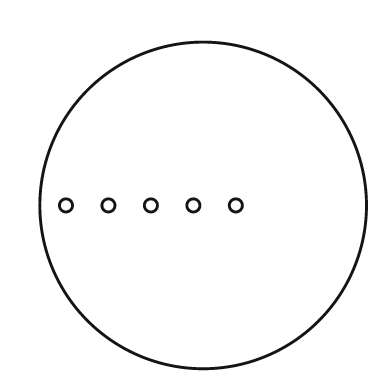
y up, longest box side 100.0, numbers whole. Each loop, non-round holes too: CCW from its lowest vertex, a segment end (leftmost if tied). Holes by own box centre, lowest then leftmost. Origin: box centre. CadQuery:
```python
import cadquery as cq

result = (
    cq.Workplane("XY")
    .moveTo(0.0, 0.0)
    .circle(50.0)
    .moveTo(-42.0, 0.0)
    .circle(2.0)
    .moveTo(-29.0, 0.0)
    .circle(2.0)
    .moveTo(-16.0, 0.0)
    .circle(2.0)
    .moveTo(-3.0, 0.0)
    .circle(2.0)
    .moveTo(10.0, 0.0)
    .circle(2.0)
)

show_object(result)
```